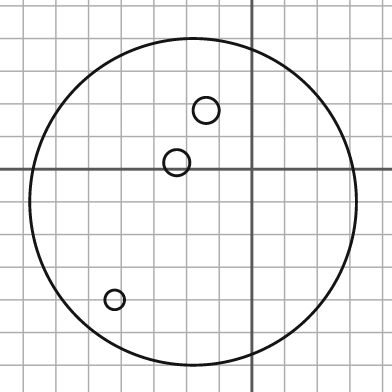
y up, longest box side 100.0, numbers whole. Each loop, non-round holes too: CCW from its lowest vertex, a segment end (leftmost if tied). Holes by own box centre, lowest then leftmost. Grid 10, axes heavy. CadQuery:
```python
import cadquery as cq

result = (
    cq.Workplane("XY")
    .moveTo(-18.0, -10.0)
    .circle(50.0)
    .moveTo(-42.0, -40.0)
    .circle(3.0)
    .moveTo(-23.0, 2.0)
    .circle(4.0)
    .moveTo(-14.0, 18.0)
    .circle(4.0)
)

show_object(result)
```